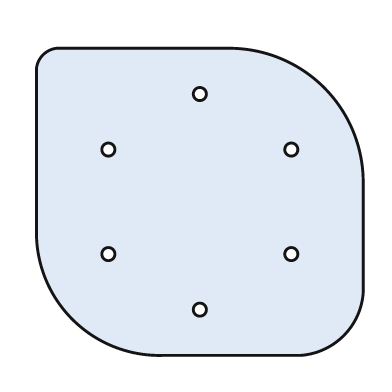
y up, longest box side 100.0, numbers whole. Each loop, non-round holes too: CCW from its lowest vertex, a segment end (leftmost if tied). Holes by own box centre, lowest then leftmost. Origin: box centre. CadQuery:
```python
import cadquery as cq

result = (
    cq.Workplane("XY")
    .moveTo(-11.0, -47.0)
    .lineTo(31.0, -47.0)
    .threePointArc((44.0, -41.0), (50.0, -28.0))
    .lineTo(50.0, 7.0)
    .threePointArc((38.0, 35.0), (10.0, 47.0))
    .lineTo(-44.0, 47.0)
    .threePointArc((-48.0, 45.0), (-50.0, 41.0))
    .lineTo(-50.0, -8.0)
    .threePointArc((-39.0, -36.0), (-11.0, -47.0))
    .close()
    .moveTo(0.0, -33.0)
    .circle(2.0)
    .moveTo(-28.0, -16.0)
    .circle(2.0)
    .moveTo(28.0, -16.0)
    .circle(2.0)
    .moveTo(-28.0, 16.0)
    .circle(2.0)
    .moveTo(28.0, 16.0)
    .circle(2.0)
    .moveTo(0.0, 33.0)
    .circle(2.0)
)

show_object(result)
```